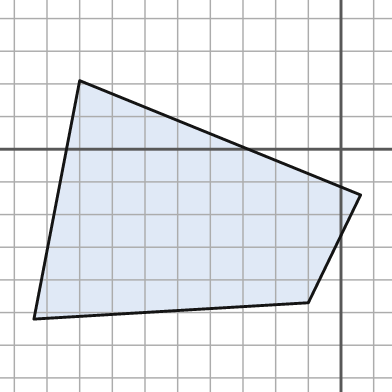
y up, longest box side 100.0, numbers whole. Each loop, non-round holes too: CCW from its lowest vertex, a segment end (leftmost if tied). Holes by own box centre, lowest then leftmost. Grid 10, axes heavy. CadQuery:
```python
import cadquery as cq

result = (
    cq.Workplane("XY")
    .moveTo(-94.0, -52.0)
    .lineTo(-10.0, -47.0)
    .lineTo(6.0, -14.0)
    .lineTo(-80.0, 21.0)
    .close()
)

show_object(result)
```